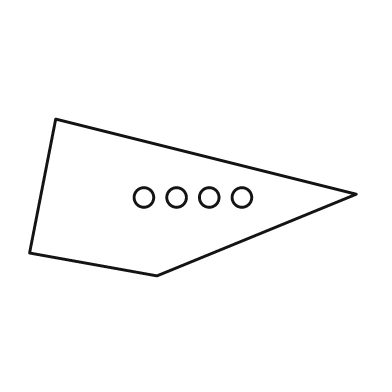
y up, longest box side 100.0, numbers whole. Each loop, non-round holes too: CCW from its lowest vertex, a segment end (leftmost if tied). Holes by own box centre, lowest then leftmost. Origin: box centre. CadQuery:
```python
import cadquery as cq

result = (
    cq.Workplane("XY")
    .moveTo(-11.0, -24.0)
    .lineTo(50.0, 1.0)
    .lineTo(-42.0, 24.0)
    .lineTo(-50.0, -17.0)
    .close()
    .moveTo(-15.0, 0.0)
    .circle(3.0)
    .moveTo(-5.0, 0.0)
    .circle(3.0)
    .moveTo(5.0, 0.0)
    .circle(3.0)
    .moveTo(15.0, 0.0)
    .circle(3.0)
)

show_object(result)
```